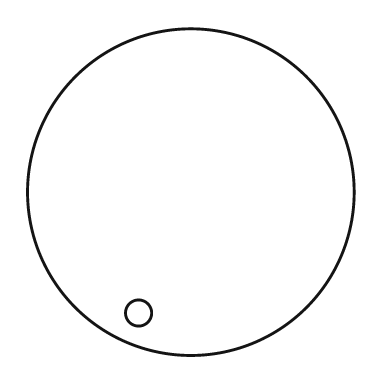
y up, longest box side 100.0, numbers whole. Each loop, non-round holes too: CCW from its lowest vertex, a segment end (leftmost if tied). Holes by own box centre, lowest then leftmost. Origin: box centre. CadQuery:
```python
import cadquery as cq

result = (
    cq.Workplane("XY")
    .moveTo(0.0, 0.0)
    .circle(50.0)
    .moveTo(-16.0, -37.0)
    .circle(4.0)
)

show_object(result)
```